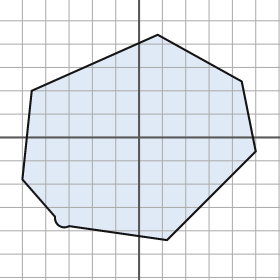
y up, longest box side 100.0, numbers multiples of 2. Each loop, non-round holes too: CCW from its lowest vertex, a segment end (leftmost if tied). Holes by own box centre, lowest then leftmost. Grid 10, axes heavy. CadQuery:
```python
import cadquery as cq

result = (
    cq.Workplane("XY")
    .moveTo(12.0, -44.0)
    .lineTo(50.0, -6.0)
    .lineTo(44.0, 24.0)
    .lineTo(8.0, 44.0)
    .lineTo(-46.0, 20.0)
    .lineTo(-50.0, -18.0)
    .lineTo(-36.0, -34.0)
    .threePointArc((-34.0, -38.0), (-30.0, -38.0))
    .close()
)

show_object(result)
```